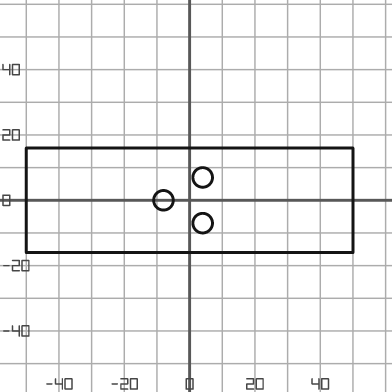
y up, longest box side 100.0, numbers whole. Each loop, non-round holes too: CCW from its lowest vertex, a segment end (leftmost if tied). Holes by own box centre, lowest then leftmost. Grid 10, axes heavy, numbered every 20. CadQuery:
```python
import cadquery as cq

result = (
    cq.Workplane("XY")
    .moveTo(-50.0, -16.0)
    .lineTo(50.0, -16.0)
    .lineTo(50.0, 16.0)
    .lineTo(-50.0, 16.0)
    .close()
    .moveTo(4.0, -7.0)
    .circle(3.0)
    .moveTo(-8.0, 0.0)
    .circle(3.0)
    .moveTo(4.0, 7.0)
    .circle(3.0)
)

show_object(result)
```